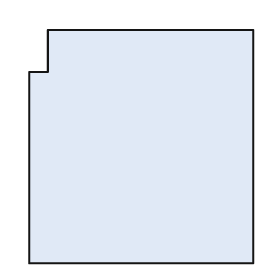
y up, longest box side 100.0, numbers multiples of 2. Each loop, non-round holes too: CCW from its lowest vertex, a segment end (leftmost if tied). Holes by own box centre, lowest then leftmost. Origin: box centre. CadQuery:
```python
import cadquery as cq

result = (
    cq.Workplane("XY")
    .moveTo(-48.0, -50.0)
    .lineTo(48.0, -50.0)
    .lineTo(48.0, 50.0)
    .lineTo(-40.0, 50.0)
    .lineTo(-40.0, 32.0)
    .lineTo(-48.0, 32.0)
    .close()
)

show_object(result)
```